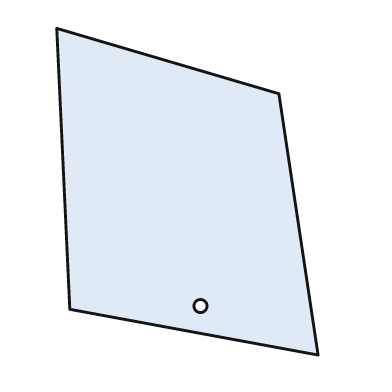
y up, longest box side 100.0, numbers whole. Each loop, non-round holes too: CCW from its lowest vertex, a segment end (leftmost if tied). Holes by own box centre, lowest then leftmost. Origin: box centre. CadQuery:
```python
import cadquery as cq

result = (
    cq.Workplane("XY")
    .moveTo(40.0, -50.0)
    .lineTo(28.0, 30.0)
    .lineTo(-40.0, 50.0)
    .lineTo(-36.0, -36.0)
    .close()
    .moveTo(4.0, -35.0)
    .circle(2.0)
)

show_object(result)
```